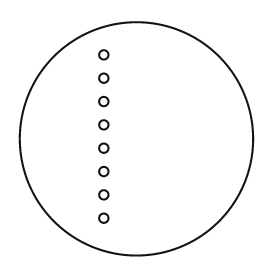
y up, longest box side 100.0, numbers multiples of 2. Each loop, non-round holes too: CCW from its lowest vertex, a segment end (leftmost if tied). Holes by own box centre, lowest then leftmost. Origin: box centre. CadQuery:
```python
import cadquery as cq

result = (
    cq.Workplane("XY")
    .moveTo(0.0, 0.0)
    .circle(50.0)
    .moveTo(-14.0, -34.0)
    .circle(2.0)
    .moveTo(-14.0, -24.0)
    .circle(2.0)
    .moveTo(-14.0, -14.0)
    .circle(2.0)
    .moveTo(-14.0, -4.0)
    .circle(2.0)
    .moveTo(-14.0, 6.0)
    .circle(2.0)
    .moveTo(-14.0, 16.0)
    .circle(2.0)
    .moveTo(-14.0, 26.0)
    .circle(2.0)
    .moveTo(-14.0, 36.0)
    .circle(2.0)
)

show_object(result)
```